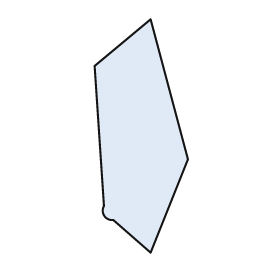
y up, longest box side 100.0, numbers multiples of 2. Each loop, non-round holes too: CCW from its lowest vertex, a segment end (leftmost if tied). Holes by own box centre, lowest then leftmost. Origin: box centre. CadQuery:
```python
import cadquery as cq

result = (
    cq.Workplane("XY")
    .moveTo(4.0, -50.0)
    .lineTo(20.0, -10.0)
    .lineTo(4.0, 50.0)
    .lineTo(-20.0, 30.0)
    .lineTo(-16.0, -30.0)
    .threePointArc((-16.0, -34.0), (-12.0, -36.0))
    .close()
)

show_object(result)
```